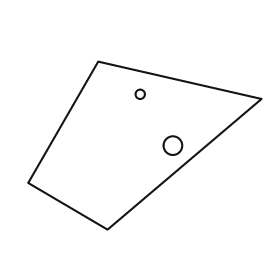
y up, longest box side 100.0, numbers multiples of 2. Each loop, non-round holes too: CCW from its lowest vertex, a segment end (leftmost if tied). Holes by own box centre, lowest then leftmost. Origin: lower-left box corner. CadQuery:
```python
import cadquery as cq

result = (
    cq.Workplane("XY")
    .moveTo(34.0, 0.0)
    .lineTo(100.0, 56.0)
    .lineTo(30.0, 72.0)
    .lineTo(0.0, 20.0)
    .close()
    .moveTo(62.0, 36.0)
    .circle(4.0)
    .moveTo(48.0, 58.0)
    .circle(2.0)
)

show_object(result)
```